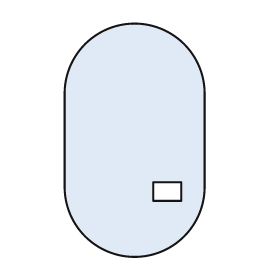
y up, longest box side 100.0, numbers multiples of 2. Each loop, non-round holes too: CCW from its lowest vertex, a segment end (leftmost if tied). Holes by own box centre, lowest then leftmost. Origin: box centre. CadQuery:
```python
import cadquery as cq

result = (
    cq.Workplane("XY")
    .moveTo(-30.0, -20.0)
    .threePointArc((0.0, -50.0), (30.0, -20.0))
    .lineTo(30.0, 20.0)
    .threePointArc((0.0, 50.0), (-30.0, 20.0))
    .close()
    .moveTo(8.0, -26.0)
    .lineTo(20.0, -26.0)
    .lineTo(20.0, -18.0)
    .lineTo(8.0, -18.0)
    .close()
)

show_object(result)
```